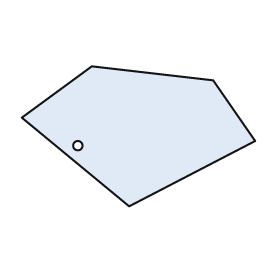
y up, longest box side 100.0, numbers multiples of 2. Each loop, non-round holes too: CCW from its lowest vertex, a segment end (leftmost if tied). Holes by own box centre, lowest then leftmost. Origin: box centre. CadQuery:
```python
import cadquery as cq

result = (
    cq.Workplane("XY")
    .moveTo(-4.0, -30.0)
    .lineTo(50.0, -2.0)
    .lineTo(32.0, 24.0)
    .lineTo(-20.0, 30.0)
    .lineTo(-50.0, 8.0)
    .close()
    .moveTo(-26.0, -4.0)
    .circle(2.0)
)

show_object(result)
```